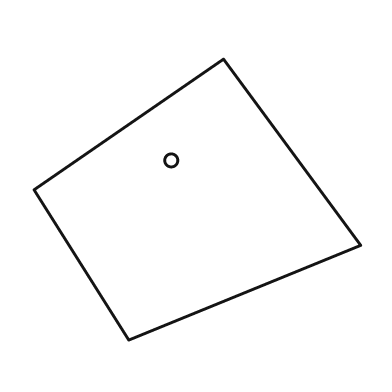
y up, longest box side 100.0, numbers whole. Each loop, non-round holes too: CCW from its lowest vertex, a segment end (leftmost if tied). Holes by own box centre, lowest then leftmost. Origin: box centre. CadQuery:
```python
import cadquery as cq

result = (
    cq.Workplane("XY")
    .moveTo(-21.0, -43.0)
    .lineTo(50.0, -14.0)
    .lineTo(8.0, 43.0)
    .lineTo(-50.0, 3.0)
    .close()
    .moveTo(-8.0, 12.0)
    .circle(2.0)
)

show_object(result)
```